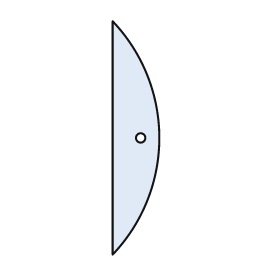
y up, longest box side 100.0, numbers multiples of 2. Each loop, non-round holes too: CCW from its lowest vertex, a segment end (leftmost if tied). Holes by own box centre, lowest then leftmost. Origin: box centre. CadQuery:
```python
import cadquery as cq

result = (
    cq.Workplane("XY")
    .moveTo(-10.0, -50.0)
    .threePointArc((10.0, 0.0), (-10.0, 50.0))
    .close()
    .moveTo(2.0, 0.0)
    .circle(2.0)
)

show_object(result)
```